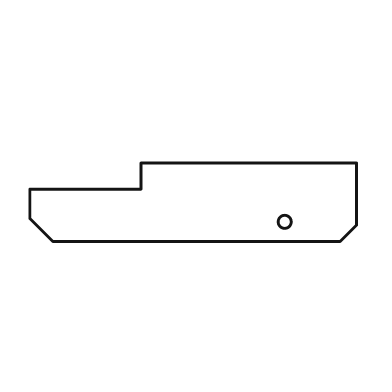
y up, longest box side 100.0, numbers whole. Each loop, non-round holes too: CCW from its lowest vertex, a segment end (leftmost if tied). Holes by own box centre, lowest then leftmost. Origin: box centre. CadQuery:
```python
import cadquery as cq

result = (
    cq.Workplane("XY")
    .moveTo(-43.0, -12.0)
    .lineTo(45.0, -12.0)
    .lineTo(50.0, -7.0)
    .lineTo(50.0, 12.0)
    .lineTo(-16.0, 12.0)
    .lineTo(-16.0, 4.0)
    .lineTo(-50.0, 4.0)
    .lineTo(-50.0, -5.0)
    .close()
    .moveTo(28.0, -6.0)
    .circle(2.0)
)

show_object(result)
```